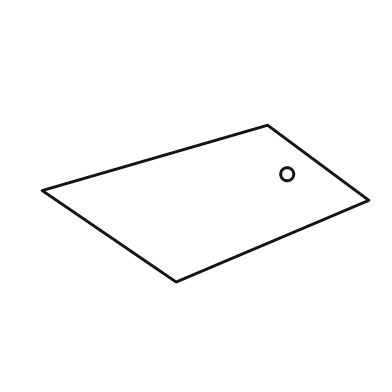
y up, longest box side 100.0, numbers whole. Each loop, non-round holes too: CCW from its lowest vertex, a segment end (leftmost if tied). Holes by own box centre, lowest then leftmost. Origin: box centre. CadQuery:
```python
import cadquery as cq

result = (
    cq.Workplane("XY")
    .moveTo(-9.0, -24.0)
    .lineTo(50.0, 1.0)
    .lineTo(19.0, 24.0)
    .lineTo(-50.0, 4.0)
    .close()
    .moveTo(25.0, 9.0)
    .circle(2.0)
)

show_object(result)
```